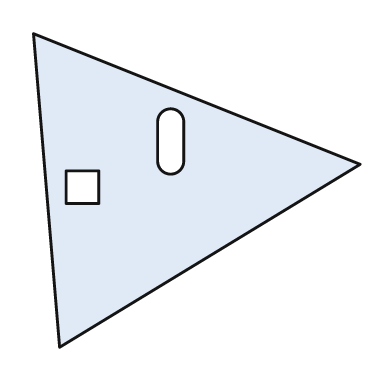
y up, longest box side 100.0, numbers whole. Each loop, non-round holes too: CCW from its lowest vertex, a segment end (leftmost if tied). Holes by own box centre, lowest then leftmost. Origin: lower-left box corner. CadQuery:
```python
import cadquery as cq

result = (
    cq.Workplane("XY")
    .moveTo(8.0, 0.0)
    .lineTo(100.0, 56.0)
    .lineTo(0.0, 96.0)
    .close()
    .moveTo(10.0, 44.0)
    .lineTo(20.0, 44.0)
    .lineTo(20.0, 54.0)
    .lineTo(10.0, 54.0)
    .close()
    .moveTo(38.0, 57.0)
    .threePointArc((42.0, 53.0), (46.0, 57.0))
    .lineTo(46.0, 69.0)
    .threePointArc((42.0, 73.0), (38.0, 69.0))
    .close()
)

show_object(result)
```